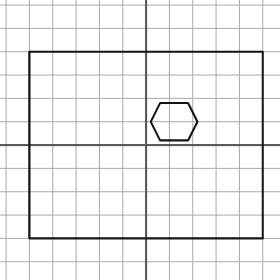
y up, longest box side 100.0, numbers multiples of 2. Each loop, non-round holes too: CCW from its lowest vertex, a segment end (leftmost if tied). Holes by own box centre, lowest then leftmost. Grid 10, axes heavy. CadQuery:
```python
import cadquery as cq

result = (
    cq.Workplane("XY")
    .moveTo(-50.0, -40.0)
    .lineTo(50.0, -40.0)
    .lineTo(50.0, 40.0)
    .lineTo(-50.0, 40.0)
    .close()
    .moveTo(6.0, 2.0)
    .lineTo(18.0, 2.0)
    .lineTo(22.0, 10.0)
    .lineTo(18.0, 18.0)
    .lineTo(6.0, 18.0)
    .lineTo(2.0, 10.0)
    .close()
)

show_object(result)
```